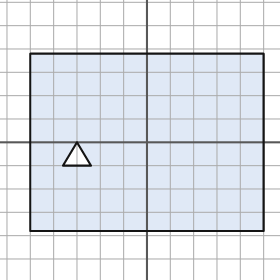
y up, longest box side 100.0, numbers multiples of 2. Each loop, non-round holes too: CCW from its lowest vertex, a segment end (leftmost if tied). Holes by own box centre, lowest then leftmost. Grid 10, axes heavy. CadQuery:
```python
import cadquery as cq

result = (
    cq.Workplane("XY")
    .moveTo(-50.0, -38.0)
    .lineTo(50.0, -38.0)
    .lineTo(50.0, 38.0)
    .lineTo(-50.0, 38.0)
    .close()
    .moveTo(-36.0, -10.0)
    .lineTo(-24.0, -10.0)
    .lineTo(-30.0, 0.0)
    .close()
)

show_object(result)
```